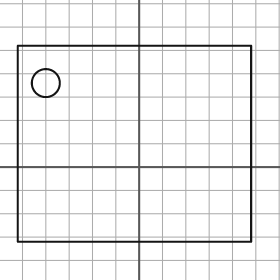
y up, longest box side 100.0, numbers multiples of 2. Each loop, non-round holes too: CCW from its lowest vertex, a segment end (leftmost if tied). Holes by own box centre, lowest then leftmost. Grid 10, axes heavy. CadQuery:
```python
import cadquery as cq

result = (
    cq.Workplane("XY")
    .moveTo(-52.0, -32.0)
    .lineTo(48.0, -32.0)
    .lineTo(48.0, 52.0)
    .lineTo(-52.0, 52.0)
    .close()
    .moveTo(-40.0, 36.0)
    .circle(6.0)
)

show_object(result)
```